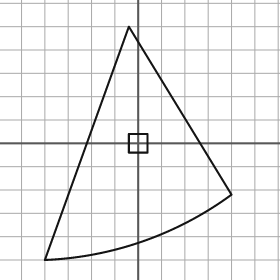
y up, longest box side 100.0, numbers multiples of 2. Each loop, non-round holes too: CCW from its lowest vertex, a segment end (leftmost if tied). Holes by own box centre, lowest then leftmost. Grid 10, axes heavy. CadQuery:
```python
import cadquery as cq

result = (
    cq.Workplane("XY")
    .moveTo(-40.0, -50.0)
    .threePointArc((2.0, -42.0), (40.0, -22.0))
    .lineTo(-4.0, 50.0)
    .close()
    .moveTo(-4.0, -4.0)
    .lineTo(4.0, -4.0)
    .lineTo(4.0, 4.0)
    .lineTo(-4.0, 4.0)
    .close()
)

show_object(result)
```